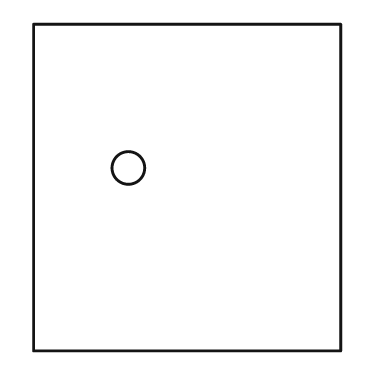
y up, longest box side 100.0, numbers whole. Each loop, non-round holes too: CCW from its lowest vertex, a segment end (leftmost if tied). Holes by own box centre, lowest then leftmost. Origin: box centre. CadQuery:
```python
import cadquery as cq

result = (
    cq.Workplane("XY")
    .moveTo(-47.0, -50.0)
    .lineTo(47.0, -50.0)
    .lineTo(47.0, 50.0)
    .lineTo(-47.0, 50.0)
    .close()
    .moveTo(-18.0, 6.0)
    .circle(5.0)
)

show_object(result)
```